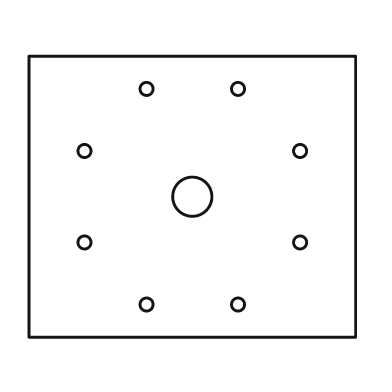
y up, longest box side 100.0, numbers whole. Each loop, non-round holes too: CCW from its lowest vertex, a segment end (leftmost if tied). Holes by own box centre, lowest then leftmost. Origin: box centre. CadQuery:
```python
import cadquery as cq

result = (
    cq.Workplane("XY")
    .moveTo(-50.0, -43.0)
    .lineTo(50.0, -43.0)
    .lineTo(50.0, 43.0)
    .lineTo(-50.0, 43.0)
    .close()
    .moveTo(-14.0, -33.0)
    .circle(2.0)
    .moveTo(14.0, -33.0)
    .circle(2.0)
    .moveTo(-33.0, -14.0)
    .circle(2.0)
    .moveTo(33.0, -14.0)
    .circle(2.0)
    .moveTo(0.0, 0.0)
    .circle(6.0)
    .moveTo(-33.0, 14.0)
    .circle(2.0)
    .moveTo(33.0, 14.0)
    .circle(2.0)
    .moveTo(-14.0, 33.0)
    .circle(2.0)
    .moveTo(14.0, 33.0)
    .circle(2.0)
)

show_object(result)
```